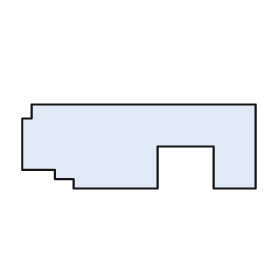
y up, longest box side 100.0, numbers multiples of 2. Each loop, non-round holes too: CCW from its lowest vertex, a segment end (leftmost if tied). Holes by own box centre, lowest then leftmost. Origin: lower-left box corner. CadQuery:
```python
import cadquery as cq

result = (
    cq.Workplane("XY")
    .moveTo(22.0, 0.0)
    .lineTo(58.0, 0.0)
    .lineTo(58.0, 18.0)
    .lineTo(82.0, 18.0)
    .lineTo(82.0, 0.0)
    .lineTo(100.0, 0.0)
    .lineTo(100.0, 36.0)
    .lineTo(4.0, 36.0)
    .lineTo(4.0, 30.0)
    .lineTo(0.0, 30.0)
    .lineTo(0.0, 8.0)
    .lineTo(14.0, 8.0)
    .lineTo(14.0, 4.0)
    .lineTo(22.0, 4.0)
    .close()
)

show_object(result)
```